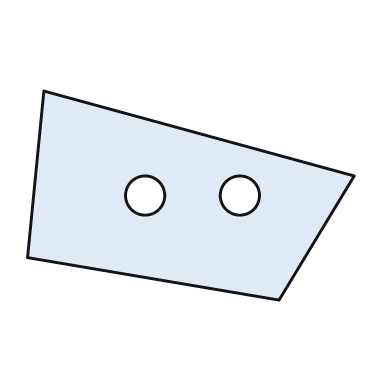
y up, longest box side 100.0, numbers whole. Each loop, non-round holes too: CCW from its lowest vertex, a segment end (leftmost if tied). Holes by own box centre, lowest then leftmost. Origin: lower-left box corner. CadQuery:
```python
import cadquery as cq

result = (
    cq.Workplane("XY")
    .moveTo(77.0, 0.0)
    .lineTo(100.0, 38.0)
    .lineTo(5.0, 64.0)
    .lineTo(0.0, 13.0)
    .close()
    .moveTo(36.0, 32.0)
    .circle(6.0)
    .moveTo(65.0, 32.0)
    .circle(6.0)
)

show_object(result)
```